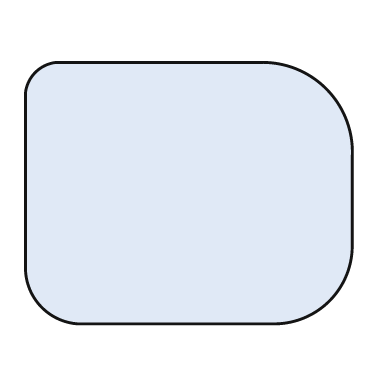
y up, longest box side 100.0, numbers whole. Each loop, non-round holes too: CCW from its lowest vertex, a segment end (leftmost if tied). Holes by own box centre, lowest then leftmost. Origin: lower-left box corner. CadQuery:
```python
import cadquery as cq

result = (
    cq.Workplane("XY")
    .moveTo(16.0, 0.0)
    .lineTo(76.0, 0.0)
    .threePointArc((93.0, 7.0), (100.0, 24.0))
    .lineTo(100.0, 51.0)
    .threePointArc((92.0, 72.0), (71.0, 80.0))
    .lineTo(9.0, 80.0)
    .threePointArc((3.0, 77.0), (0.0, 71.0))
    .lineTo(0.0, 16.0)
    .threePointArc((5.0, 5.0), (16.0, 0.0))
    .close()
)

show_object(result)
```